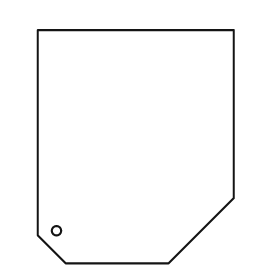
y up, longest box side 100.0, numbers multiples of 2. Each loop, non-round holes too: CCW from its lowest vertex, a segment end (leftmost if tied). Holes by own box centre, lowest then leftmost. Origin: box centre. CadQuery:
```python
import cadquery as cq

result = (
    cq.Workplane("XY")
    .moveTo(-30.0, -50.0)
    .lineTo(14.0, -50.0)
    .lineTo(42.0, -22.0)
    .lineTo(42.0, 50.0)
    .lineTo(-42.0, 50.0)
    .lineTo(-42.0, -38.0)
    .close()
    .moveTo(-34.0, -36.0)
    .circle(2.0)
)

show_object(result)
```